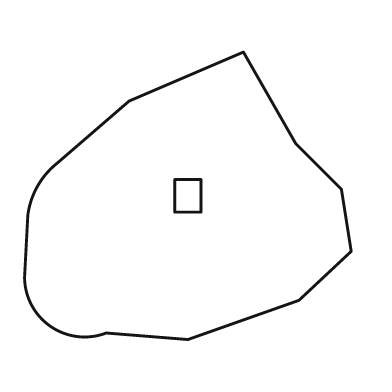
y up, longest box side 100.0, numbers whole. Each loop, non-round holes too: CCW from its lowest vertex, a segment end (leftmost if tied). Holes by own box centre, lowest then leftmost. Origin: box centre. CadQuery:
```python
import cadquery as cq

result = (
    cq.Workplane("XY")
    .moveTo(0.0, -44.0)
    .lineTo(34.0, -32.0)
    .lineTo(50.0, -17.0)
    .lineTo(47.0, 2.0)
    .lineTo(33.0, 16.0)
    .lineTo(17.0, 44.0)
    .lineTo(-18.0, 29.0)
    .lineTo(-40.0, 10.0)
    .threePointArc((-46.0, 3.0), (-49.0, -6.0))
    .lineTo(-50.0, -25.0)
    .threePointArc((-42.0, -40.0), (-25.0, -42.0))
    .close()
    .moveTo(-4.0, -5.0)
    .lineTo(4.0, -5.0)
    .lineTo(4.0, 5.0)
    .lineTo(-4.0, 5.0)
    .close()
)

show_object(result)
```